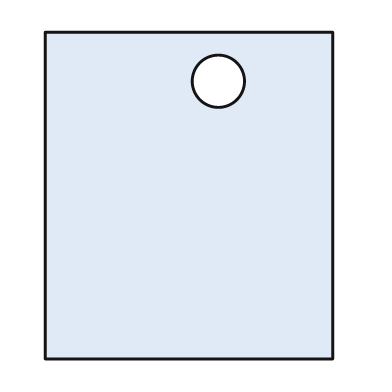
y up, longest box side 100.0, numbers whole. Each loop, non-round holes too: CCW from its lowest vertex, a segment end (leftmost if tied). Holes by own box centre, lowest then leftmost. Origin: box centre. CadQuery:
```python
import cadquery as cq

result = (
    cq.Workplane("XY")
    .moveTo(-44.0, -50.0)
    .lineTo(44.0, -50.0)
    .lineTo(44.0, 50.0)
    .lineTo(-44.0, 50.0)
    .close()
    .moveTo(9.0, 35.0)
    .circle(8.0)
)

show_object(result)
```